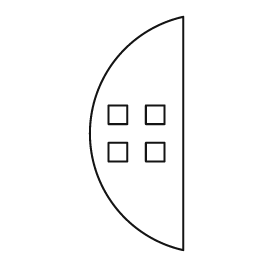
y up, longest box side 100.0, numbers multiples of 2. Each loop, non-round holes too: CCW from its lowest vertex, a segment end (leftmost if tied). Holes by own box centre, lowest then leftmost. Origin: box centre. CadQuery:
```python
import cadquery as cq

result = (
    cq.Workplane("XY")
    .moveTo(20.0, -50.0)
    .lineTo(20.0, 50.0)
    .threePointArc((-20.0, 0.0), (20.0, -50.0))
    .close()
    .moveTo(-12.0, -12.0)
    .lineTo(-4.0, -12.0)
    .lineTo(-4.0, -4.0)
    .lineTo(-12.0, -4.0)
    .close()
    .moveTo(4.0, -12.0)
    .lineTo(12.0, -12.0)
    .lineTo(12.0, -4.0)
    .lineTo(4.0, -4.0)
    .close()
    .moveTo(-12.0, 4.0)
    .lineTo(-4.0, 4.0)
    .lineTo(-4.0, 12.0)
    .lineTo(-12.0, 12.0)
    .close()
    .moveTo(4.0, 4.0)
    .lineTo(12.0, 4.0)
    .lineTo(12.0, 12.0)
    .lineTo(4.0, 12.0)
    .close()
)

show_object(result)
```